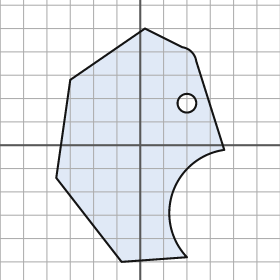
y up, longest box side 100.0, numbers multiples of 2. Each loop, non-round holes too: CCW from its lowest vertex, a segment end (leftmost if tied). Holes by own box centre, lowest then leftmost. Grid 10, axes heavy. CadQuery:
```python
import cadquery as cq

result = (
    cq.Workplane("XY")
    .moveTo(-8.0, -50.0)
    .lineTo(20.0, -48.0)
    .threePointArc((14.0, -20.0), (36.0, -2.0))
    .lineTo(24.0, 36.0)
    .threePointArc((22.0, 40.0), (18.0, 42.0))
    .lineTo(2.0, 50.0)
    .lineTo(-30.0, 28.0)
    .lineTo(-36.0, -14.0)
    .close()
    .moveTo(20.0, 18.0)
    .circle(4.0)
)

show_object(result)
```